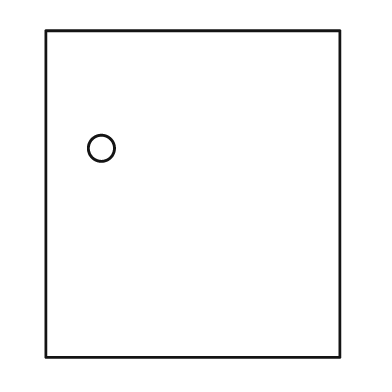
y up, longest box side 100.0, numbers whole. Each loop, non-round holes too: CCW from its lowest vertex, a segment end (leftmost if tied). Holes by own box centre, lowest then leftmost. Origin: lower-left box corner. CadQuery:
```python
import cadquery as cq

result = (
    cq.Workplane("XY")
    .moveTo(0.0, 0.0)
    .lineTo(90.0, 0.0)
    .lineTo(90.0, 100.0)
    .lineTo(0.0, 100.0)
    .close()
    .moveTo(17.0, 64.0)
    .circle(4.0)
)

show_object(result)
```